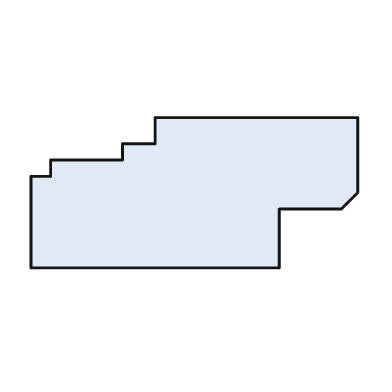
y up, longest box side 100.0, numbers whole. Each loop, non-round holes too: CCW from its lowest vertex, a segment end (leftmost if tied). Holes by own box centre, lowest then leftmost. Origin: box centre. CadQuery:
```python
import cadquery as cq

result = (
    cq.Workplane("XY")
    .moveTo(-50.0, -23.0)
    .lineTo(26.0, -23.0)
    .lineTo(26.0, -5.0)
    .lineTo(45.0, -5.0)
    .lineTo(50.0, 0.0)
    .lineTo(50.0, 23.0)
    .lineTo(-12.0, 23.0)
    .lineTo(-12.0, 15.0)
    .lineTo(-22.0, 15.0)
    .lineTo(-22.0, 10.0)
    .lineTo(-44.0, 10.0)
    .lineTo(-44.0, 5.0)
    .lineTo(-50.0, 5.0)
    .close()
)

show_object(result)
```